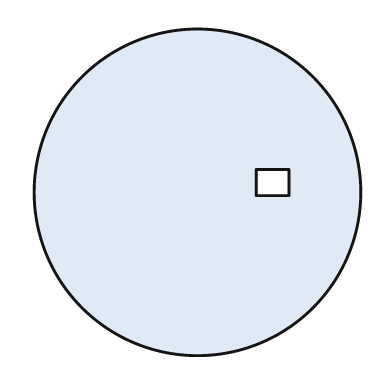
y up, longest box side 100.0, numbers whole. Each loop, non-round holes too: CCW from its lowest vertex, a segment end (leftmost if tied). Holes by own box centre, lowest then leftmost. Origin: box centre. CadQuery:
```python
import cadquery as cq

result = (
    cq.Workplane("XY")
    .moveTo(0.0, 0.0)
    .circle(50.0)
    .moveTo(18.0, -1.0)
    .lineTo(28.0, -1.0)
    .lineTo(28.0, 7.0)
    .lineTo(18.0, 7.0)
    .close()
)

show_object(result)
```